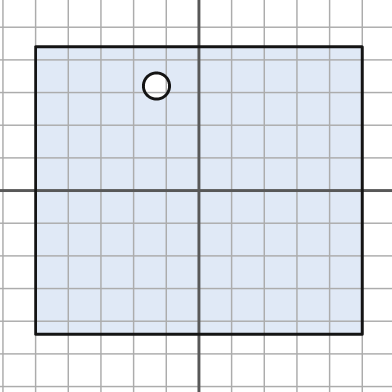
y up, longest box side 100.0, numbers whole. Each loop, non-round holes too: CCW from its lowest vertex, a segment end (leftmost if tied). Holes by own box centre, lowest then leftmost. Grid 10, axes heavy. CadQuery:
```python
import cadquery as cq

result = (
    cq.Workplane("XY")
    .moveTo(-50.0, -44.0)
    .lineTo(50.0, -44.0)
    .lineTo(50.0, 44.0)
    .lineTo(-50.0, 44.0)
    .close()
    .moveTo(-13.0, 32.0)
    .circle(4.0)
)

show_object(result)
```